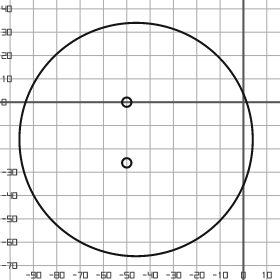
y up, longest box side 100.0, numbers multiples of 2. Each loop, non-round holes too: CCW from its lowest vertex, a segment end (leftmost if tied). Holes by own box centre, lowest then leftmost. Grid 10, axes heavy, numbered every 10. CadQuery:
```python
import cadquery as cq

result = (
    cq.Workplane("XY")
    .moveTo(-46.0, -16.0)
    .circle(50.0)
    .moveTo(-50.0, -26.0)
    .circle(2.0)
    .moveTo(-50.0, 0.0)
    .circle(2.0)
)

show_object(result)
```